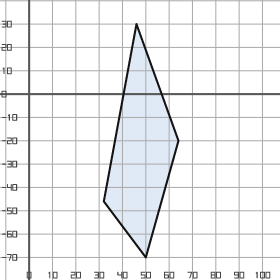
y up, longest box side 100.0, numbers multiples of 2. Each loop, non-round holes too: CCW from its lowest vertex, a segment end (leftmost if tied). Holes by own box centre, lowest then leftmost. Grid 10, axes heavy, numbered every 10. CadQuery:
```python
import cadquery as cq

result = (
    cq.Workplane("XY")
    .moveTo(50.0, -70.0)
    .lineTo(64.0, -20.0)
    .lineTo(46.0, 30.0)
    .lineTo(32.0, -46.0)
    .close()
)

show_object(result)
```